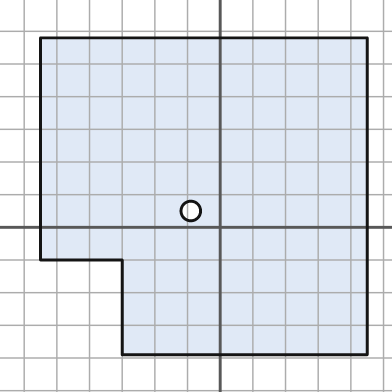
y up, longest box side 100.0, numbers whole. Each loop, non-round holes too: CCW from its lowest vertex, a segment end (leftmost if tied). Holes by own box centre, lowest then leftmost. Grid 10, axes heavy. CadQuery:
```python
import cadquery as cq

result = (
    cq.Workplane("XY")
    .moveTo(-30.0, -39.0)
    .lineTo(45.0, -39.0)
    .lineTo(45.0, 58.0)
    .lineTo(-55.0, 58.0)
    .lineTo(-55.0, -10.0)
    .lineTo(-30.0, -10.0)
    .close()
    .moveTo(-9.0, 5.0)
    .circle(3.0)
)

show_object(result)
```